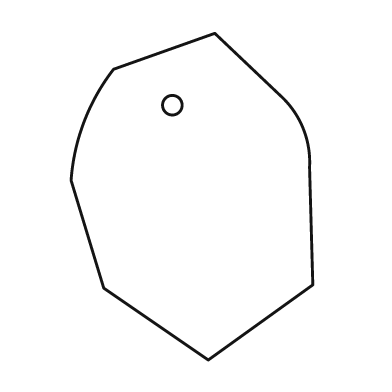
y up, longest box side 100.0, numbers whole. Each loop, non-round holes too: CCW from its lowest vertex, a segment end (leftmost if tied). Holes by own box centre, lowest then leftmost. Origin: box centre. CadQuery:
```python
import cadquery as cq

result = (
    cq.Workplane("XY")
    .moveTo(5.0, -50.0)
    .lineTo(37.0, -27.0)
    .lineTo(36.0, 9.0)
    .threePointArc((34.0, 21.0), (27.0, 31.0))
    .lineTo(7.0, 50.0)
    .lineTo(-24.0, 39.0)
    .threePointArc((-33.0, 23.0), (-37.0, 5.0))
    .lineTo(-27.0, -28.0)
    .close()
    .moveTo(-6.0, 28.0)
    .circle(3.0)
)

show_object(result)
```